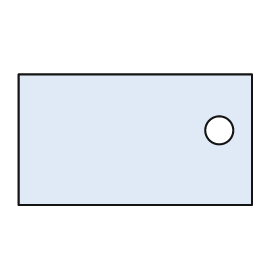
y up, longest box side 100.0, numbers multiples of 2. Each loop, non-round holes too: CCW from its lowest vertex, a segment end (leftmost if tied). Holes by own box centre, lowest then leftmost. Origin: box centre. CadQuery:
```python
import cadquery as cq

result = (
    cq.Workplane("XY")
    .moveTo(-50.0, -28.0)
    .lineTo(50.0, -28.0)
    .lineTo(50.0, 28.0)
    .lineTo(-50.0, 28.0)
    .close()
    .moveTo(36.0, 4.0)
    .circle(6.0)
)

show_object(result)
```